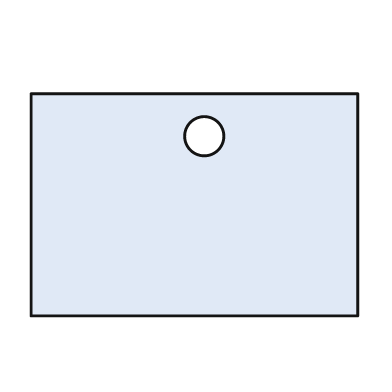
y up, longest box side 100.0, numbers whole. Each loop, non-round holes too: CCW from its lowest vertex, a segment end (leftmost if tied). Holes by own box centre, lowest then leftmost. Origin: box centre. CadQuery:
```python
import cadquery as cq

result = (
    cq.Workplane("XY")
    .moveTo(-50.0, -34.0)
    .lineTo(50.0, -34.0)
    .lineTo(50.0, 34.0)
    .lineTo(-50.0, 34.0)
    .close()
    .moveTo(3.0, 21.0)
    .circle(6.0)
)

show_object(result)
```